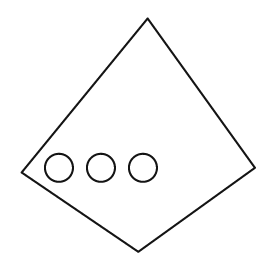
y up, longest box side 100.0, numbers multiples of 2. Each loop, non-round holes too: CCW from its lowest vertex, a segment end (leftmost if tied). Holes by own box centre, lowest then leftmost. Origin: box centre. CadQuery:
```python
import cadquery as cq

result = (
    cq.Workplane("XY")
    .moveTo(0.0, -50.0)
    .lineTo(50.0, -14.0)
    .lineTo(4.0, 50.0)
    .lineTo(-50.0, -16.0)
    .close()
    .moveTo(-34.0, -14.0)
    .circle(6.0)
    .moveTo(-16.0, -14.0)
    .circle(6.0)
    .moveTo(2.0, -14.0)
    .circle(6.0)
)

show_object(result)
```